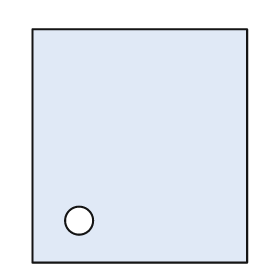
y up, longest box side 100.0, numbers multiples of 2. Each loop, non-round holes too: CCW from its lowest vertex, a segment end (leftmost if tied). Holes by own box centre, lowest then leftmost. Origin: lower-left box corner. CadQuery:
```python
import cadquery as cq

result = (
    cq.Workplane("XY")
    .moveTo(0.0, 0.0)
    .lineTo(92.0, 0.0)
    .lineTo(92.0, 100.0)
    .lineTo(0.0, 100.0)
    .close()
    .moveTo(20.0, 18.0)
    .circle(6.0)
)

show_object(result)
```